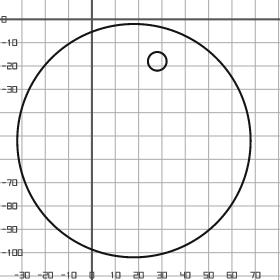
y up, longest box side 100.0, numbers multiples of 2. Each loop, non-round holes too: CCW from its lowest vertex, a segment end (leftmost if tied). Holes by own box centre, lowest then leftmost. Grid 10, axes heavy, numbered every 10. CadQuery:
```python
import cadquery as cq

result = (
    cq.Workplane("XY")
    .moveTo(18.0, -52.0)
    .circle(50.0)
    .moveTo(28.0, -18.0)
    .circle(4.0)
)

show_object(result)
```